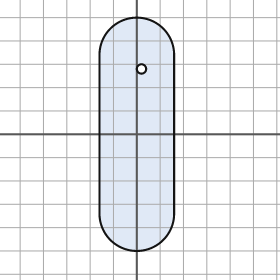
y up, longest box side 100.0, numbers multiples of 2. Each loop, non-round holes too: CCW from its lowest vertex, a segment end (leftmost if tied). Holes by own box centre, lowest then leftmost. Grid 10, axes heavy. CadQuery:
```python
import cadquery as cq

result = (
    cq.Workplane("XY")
    .moveTo(-16.0, -34.0)
    .threePointArc((0.0, -50.0), (16.0, -34.0))
    .lineTo(16.0, 34.0)
    .threePointArc((0.0, 50.0), (-16.0, 34.0))
    .close()
    .moveTo(2.0, 28.0)
    .circle(2.0)
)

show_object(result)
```